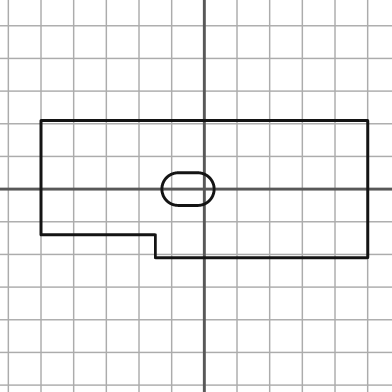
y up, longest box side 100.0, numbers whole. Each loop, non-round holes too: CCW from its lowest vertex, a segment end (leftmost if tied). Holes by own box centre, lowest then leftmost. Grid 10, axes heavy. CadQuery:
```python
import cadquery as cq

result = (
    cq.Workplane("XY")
    .moveTo(-15.0, -21.0)
    .lineTo(50.0, -21.0)
    .lineTo(50.0, 21.0)
    .lineTo(-50.0, 21.0)
    .lineTo(-50.0, -14.0)
    .lineTo(-15.0, -14.0)
    .close()
    .moveTo(-8.0, -5.0)
    .lineTo(-2.0, -5.0)
    .threePointArc((3.0, 0.0), (-2.0, 5.0))
    .lineTo(-8.0, 5.0)
    .threePointArc((-13.0, 0.0), (-8.0, -5.0))
    .close()
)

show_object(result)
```